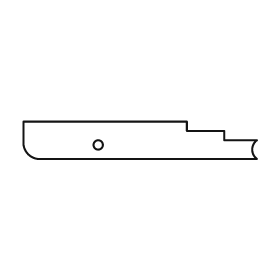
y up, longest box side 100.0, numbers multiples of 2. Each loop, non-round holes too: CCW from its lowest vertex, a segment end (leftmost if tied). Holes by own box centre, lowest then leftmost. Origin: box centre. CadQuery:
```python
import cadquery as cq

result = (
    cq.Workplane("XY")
    .moveTo(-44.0, -8.0)
    .lineTo(50.0, -8.0)
    .threePointArc((48.0, -4.0), (50.0, 0.0))
    .lineTo(36.0, 0.0)
    .lineTo(36.0, 4.0)
    .lineTo(20.0, 4.0)
    .lineTo(20.0, 8.0)
    .lineTo(-50.0, 8.0)
    .lineTo(-50.0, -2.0)
    .threePointArc((-48.0, -6.0), (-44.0, -8.0))
    .close()
    .moveTo(-18.0, -2.0)
    .circle(2.0)
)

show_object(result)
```